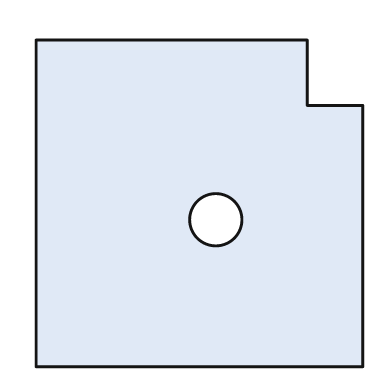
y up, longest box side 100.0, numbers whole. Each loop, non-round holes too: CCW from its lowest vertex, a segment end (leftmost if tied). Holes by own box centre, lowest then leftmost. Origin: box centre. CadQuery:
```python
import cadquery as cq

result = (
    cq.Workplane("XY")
    .moveTo(-50.0, -50.0)
    .lineTo(50.0, -50.0)
    .lineTo(50.0, 30.0)
    .lineTo(33.0, 30.0)
    .lineTo(33.0, 50.0)
    .lineTo(-50.0, 50.0)
    .close()
    .moveTo(5.0, -5.0)
    .circle(8.0)
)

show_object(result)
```